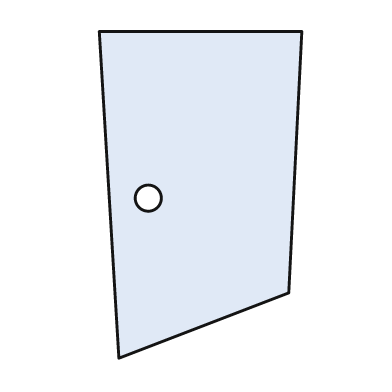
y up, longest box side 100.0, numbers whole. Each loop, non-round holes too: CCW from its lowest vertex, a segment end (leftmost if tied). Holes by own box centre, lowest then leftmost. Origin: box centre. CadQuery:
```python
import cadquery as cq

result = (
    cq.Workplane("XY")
    .moveTo(-25.0, -50.0)
    .lineTo(27.0, -30.0)
    .lineTo(31.0, 50.0)
    .lineTo(-31.0, 50.0)
    .close()
    .moveTo(-16.0, -1.0)
    .circle(4.0)
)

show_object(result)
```